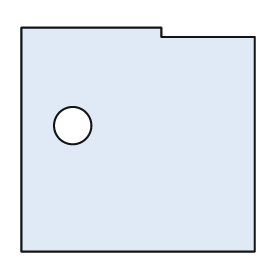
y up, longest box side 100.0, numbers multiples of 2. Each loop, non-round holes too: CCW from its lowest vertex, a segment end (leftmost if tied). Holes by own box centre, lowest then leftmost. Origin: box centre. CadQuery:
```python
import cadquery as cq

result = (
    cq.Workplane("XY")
    .moveTo(-50.0, -48.0)
    .lineTo(50.0, -48.0)
    .lineTo(50.0, 44.0)
    .lineTo(10.0, 44.0)
    .lineTo(10.0, 48.0)
    .lineTo(-50.0, 48.0)
    .close()
    .moveTo(-28.0, 6.0)
    .circle(8.0)
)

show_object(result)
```